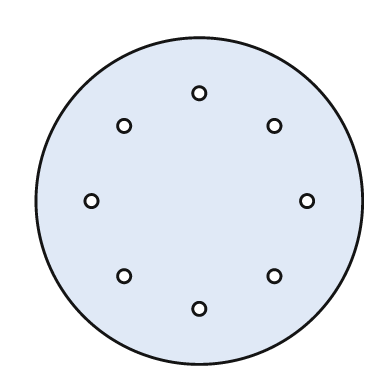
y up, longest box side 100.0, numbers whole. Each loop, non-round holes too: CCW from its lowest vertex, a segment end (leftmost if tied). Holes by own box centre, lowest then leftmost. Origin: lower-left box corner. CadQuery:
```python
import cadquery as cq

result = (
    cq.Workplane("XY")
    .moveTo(50.0, 50.0)
    .circle(50.0)
    .moveTo(50.0, 17.0)
    .circle(2.0)
    .moveTo(27.0, 27.0)
    .circle(2.0)
    .moveTo(73.0, 27.0)
    .circle(2.0)
    .moveTo(17.0, 50.0)
    .circle(2.0)
    .moveTo(83.0, 50.0)
    .circle(2.0)
    .moveTo(27.0, 73.0)
    .circle(2.0)
    .moveTo(73.0, 73.0)
    .circle(2.0)
    .moveTo(50.0, 83.0)
    .circle(2.0)
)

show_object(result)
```